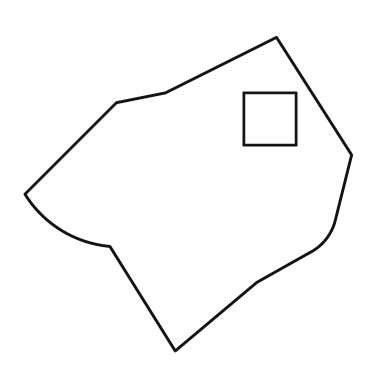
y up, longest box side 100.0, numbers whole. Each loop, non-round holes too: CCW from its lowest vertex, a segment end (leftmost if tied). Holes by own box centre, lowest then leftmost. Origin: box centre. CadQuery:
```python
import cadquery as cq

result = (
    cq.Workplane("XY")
    .moveTo(-4.0, -48.0)
    .lineTo(21.0, -27.0)
    .lineTo(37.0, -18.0)
    .threePointArc((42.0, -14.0), (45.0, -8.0))
    .lineTo(50.0, 12.0)
    .lineTo(27.0, 48.0)
    .lineTo(-7.0, 31.0)
    .lineTo(-22.0, 28.0)
    .lineTo(-50.0, 0.0)
    .threePointArc((-39.0, -11.0), (-24.0, -16.0))
    .close()
    .moveTo(17.0, 15.0)
    .lineTo(33.0, 15.0)
    .lineTo(33.0, 31.0)
    .lineTo(17.0, 31.0)
    .close()
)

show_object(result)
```